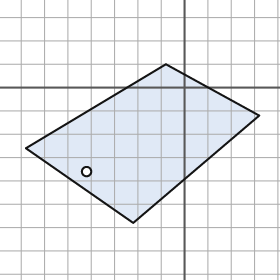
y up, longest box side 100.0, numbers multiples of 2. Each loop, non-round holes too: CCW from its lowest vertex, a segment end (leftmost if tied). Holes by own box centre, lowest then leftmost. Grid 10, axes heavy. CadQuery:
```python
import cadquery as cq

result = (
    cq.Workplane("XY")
    .moveTo(-22.0, -58.0)
    .lineTo(32.0, -12.0)
    .lineTo(-8.0, 10.0)
    .lineTo(-68.0, -26.0)
    .close()
    .moveTo(-42.0, -36.0)
    .circle(2.0)
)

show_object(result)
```